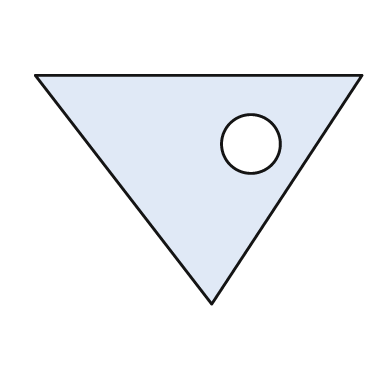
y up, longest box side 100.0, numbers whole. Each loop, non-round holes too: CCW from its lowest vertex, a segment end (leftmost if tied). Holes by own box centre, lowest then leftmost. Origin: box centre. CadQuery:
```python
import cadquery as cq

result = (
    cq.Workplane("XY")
    .moveTo(4.0, -35.0)
    .lineTo(50.0, 35.0)
    .lineTo(-50.0, 35.0)
    .close()
    .moveTo(16.0, 14.0)
    .circle(9.0)
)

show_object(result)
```